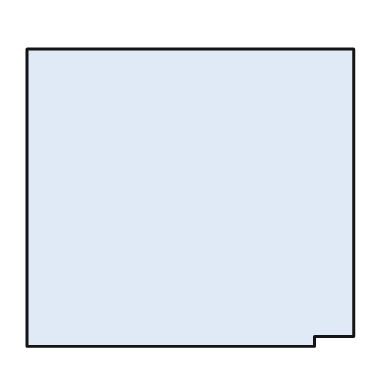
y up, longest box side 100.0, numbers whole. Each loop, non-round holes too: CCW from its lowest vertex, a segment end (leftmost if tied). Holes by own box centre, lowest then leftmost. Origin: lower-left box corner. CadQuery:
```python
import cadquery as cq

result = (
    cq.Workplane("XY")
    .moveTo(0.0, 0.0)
    .lineTo(88.0, 0.0)
    .lineTo(88.0, 3.0)
    .lineTo(100.0, 3.0)
    .lineTo(100.0, 91.0)
    .lineTo(0.0, 91.0)
    .close()
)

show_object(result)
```